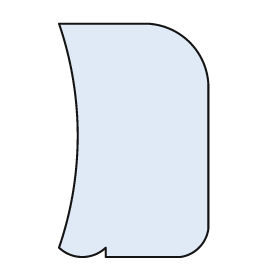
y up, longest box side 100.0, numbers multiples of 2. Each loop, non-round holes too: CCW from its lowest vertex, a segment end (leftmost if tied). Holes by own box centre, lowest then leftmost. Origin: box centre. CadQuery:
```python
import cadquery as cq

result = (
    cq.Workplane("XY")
    .moveTo(-12.0, -50.0)
    .lineTo(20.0, -50.0)
    .threePointArc((28.0, -46.0), (32.0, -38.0))
    .lineTo(32.0, 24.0)
    .threePointArc((24.0, 42.0), (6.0, 50.0))
    .lineTo(-32.0, 50.0)
    .threePointArc((-24.0, 2.0), (-32.0, -46.0))
    .threePointArc((-22.0, -50.0), (-12.0, -46.0))
    .close()
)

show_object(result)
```